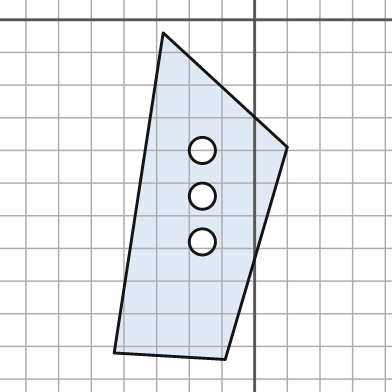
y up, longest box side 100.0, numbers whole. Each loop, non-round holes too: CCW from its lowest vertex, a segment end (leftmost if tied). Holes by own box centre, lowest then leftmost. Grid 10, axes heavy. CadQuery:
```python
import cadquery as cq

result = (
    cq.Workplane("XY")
    .moveTo(-9.0, -104.0)
    .lineTo(10.0, -39.0)
    .lineTo(-28.0, -4.0)
    .lineTo(-43.0, -102.0)
    .close()
    .moveTo(-16.0, -68.0)
    .circle(4.0)
    .moveTo(-16.0, -54.0)
    .circle(4.0)
    .moveTo(-16.0, -40.0)
    .circle(4.0)
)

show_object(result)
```